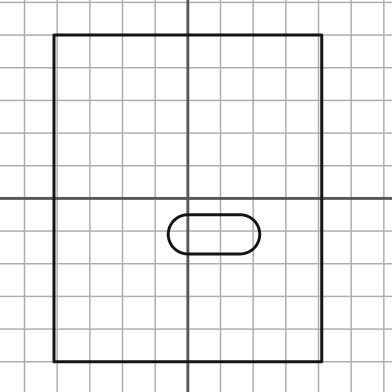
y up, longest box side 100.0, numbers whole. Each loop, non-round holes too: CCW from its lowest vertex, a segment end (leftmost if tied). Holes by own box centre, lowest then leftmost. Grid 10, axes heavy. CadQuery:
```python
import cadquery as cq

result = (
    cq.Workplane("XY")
    .moveTo(-41.0, -50.0)
    .lineTo(41.0, -50.0)
    .lineTo(41.0, 50.0)
    .lineTo(-41.0, 50.0)
    .close()
    .moveTo(0.0, -17.0)
    .lineTo(16.0, -17.0)
    .threePointArc((22.0, -11.0), (16.0, -5.0))
    .lineTo(0.0, -5.0)
    .threePointArc((-6.0, -11.0), (0.0, -17.0))
    .close()
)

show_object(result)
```